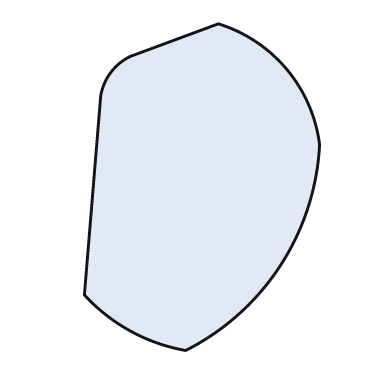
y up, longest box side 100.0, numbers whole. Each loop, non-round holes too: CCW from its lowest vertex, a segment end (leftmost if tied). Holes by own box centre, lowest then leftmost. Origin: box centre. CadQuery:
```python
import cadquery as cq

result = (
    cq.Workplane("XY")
    .moveTo(-5.0, -50.0)
    .threePointArc((24.0, -24.0), (36.0, 13.0))
    .threePointArc((26.0, 36.0), (5.0, 50.0))
    .lineTo(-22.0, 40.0)
    .threePointArc((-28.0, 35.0), (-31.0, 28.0))
    .lineTo(-36.0, -33.0)
    .threePointArc((-22.0, -44.0), (-5.0, -50.0))
    .close()
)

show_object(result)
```